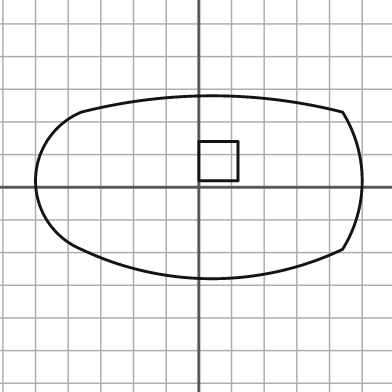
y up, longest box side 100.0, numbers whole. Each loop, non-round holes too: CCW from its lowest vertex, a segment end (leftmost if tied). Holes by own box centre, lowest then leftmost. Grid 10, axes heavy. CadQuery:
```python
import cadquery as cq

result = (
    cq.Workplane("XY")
    .moveTo(-36.0, -19.0)
    .threePointArc((4.0, -28.0), (44.0, -19.0))
    .threePointArc((50.0, 2.0), (44.0, 23.0))
    .threePointArc((4.0, 28.0), (-36.0, 23.0))
    .threePointArc((-50.0, 2.0), (-36.0, -19.0))
    .close()
    .moveTo(0.0, 2.0)
    .lineTo(12.0, 2.0)
    .lineTo(12.0, 14.0)
    .lineTo(0.0, 14.0)
    .close()
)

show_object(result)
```